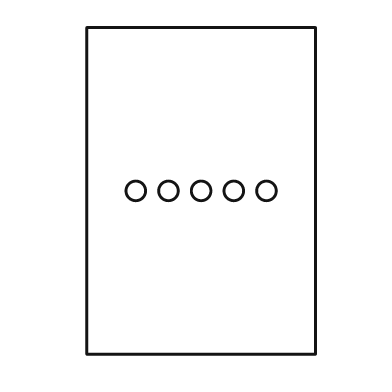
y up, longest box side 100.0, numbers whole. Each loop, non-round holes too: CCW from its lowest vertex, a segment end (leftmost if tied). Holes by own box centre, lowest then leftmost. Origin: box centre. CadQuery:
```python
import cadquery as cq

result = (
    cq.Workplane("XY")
    .moveTo(-35.0, -50.0)
    .lineTo(35.0, -50.0)
    .lineTo(35.0, 50.0)
    .lineTo(-35.0, 50.0)
    .close()
    .moveTo(-20.0, 0.0)
    .circle(3.0)
    .moveTo(-10.0, 0.0)
    .circle(3.0)
    .moveTo(0.0, 0.0)
    .circle(3.0)
    .moveTo(10.0, 0.0)
    .circle(3.0)
    .moveTo(20.0, 0.0)
    .circle(3.0)
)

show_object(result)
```